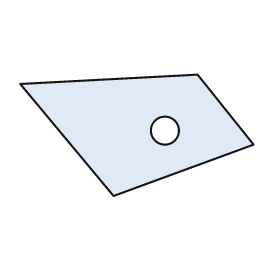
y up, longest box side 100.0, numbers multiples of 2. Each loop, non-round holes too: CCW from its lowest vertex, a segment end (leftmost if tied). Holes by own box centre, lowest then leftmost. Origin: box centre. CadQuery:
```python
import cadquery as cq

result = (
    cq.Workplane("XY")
    .moveTo(-10.0, -26.0)
    .lineTo(50.0, -4.0)
    .lineTo(26.0, 26.0)
    .lineTo(-50.0, 22.0)
    .close()
    .moveTo(12.0, 2.0)
    .circle(6.0)
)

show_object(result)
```